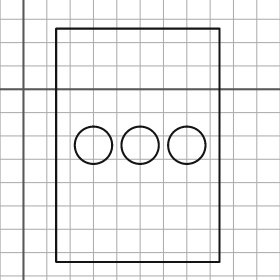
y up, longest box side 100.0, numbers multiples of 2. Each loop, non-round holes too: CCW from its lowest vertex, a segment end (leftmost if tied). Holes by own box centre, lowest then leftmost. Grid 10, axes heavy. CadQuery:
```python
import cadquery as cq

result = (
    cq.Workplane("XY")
    .moveTo(14.0, -74.0)
    .lineTo(84.0, -74.0)
    .lineTo(84.0, 26.0)
    .lineTo(14.0, 26.0)
    .close()
    .moveTo(30.0, -24.0)
    .circle(8.0)
    .moveTo(50.0, -24.0)
    .circle(8.0)
    .moveTo(70.0, -24.0)
    .circle(8.0)
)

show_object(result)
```